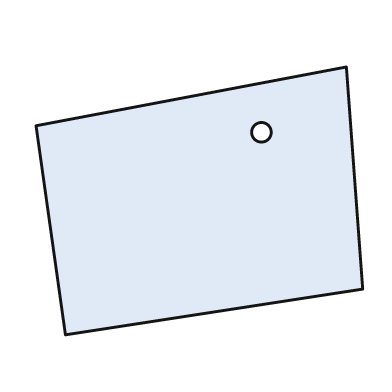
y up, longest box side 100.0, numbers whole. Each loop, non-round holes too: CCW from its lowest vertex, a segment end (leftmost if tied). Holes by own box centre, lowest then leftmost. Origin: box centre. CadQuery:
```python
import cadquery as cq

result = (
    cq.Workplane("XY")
    .moveTo(-41.0, -41.0)
    .lineTo(50.0, -27.0)
    .lineTo(45.0, 41.0)
    .lineTo(-50.0, 23.0)
    .close()
    .moveTo(19.0, 21.0)
    .circle(3.0)
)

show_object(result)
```